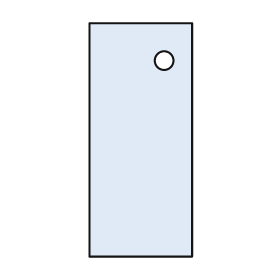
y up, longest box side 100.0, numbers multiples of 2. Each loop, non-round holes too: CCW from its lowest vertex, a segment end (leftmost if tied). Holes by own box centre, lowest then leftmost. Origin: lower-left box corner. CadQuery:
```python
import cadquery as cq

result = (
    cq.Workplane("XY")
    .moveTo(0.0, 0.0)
    .lineTo(44.0, 0.0)
    .lineTo(44.0, 100.0)
    .lineTo(0.0, 100.0)
    .close()
    .moveTo(32.0, 84.0)
    .circle(4.0)
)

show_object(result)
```